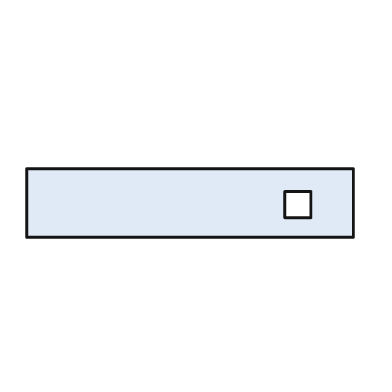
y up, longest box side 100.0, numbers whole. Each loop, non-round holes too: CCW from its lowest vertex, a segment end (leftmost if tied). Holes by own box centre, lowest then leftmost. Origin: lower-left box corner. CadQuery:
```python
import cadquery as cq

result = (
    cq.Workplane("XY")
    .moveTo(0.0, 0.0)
    .lineTo(100.0, 0.0)
    .lineTo(100.0, 21.0)
    .lineTo(0.0, 21.0)
    .close()
    .moveTo(79.0, 6.0)
    .lineTo(87.0, 6.0)
    .lineTo(87.0, 14.0)
    .lineTo(79.0, 14.0)
    .close()
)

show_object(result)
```